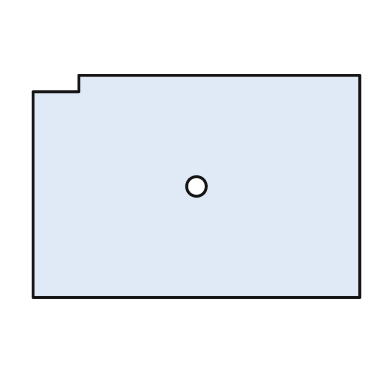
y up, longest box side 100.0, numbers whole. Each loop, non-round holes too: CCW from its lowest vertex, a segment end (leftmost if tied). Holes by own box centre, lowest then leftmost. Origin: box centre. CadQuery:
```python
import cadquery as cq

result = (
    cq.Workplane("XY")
    .moveTo(-50.0, -34.0)
    .lineTo(50.0, -34.0)
    .lineTo(50.0, 34.0)
    .lineTo(-36.0, 34.0)
    .lineTo(-36.0, 29.0)
    .lineTo(-50.0, 29.0)
    .close()
    .moveTo(0.0, 0.0)
    .circle(3.0)
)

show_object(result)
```